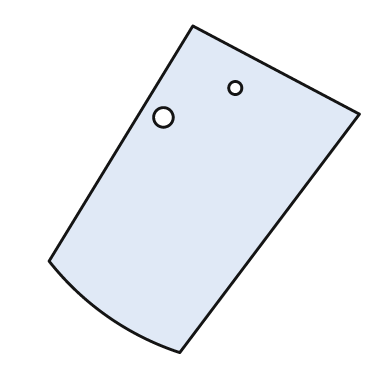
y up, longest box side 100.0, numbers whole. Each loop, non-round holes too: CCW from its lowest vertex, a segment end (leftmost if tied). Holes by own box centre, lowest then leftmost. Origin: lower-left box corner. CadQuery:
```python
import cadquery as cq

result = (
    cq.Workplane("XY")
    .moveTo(40.0, 0.0)
    .lineTo(95.0, 73.0)
    .lineTo(44.0, 100.0)
    .lineTo(0.0, 28.0)
    .threePointArc((18.0, 11.0), (40.0, 0.0))
    .close()
    .moveTo(35.0, 72.0)
    .circle(3.0)
    .moveTo(57.0, 81.0)
    .circle(2.0)
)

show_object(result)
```